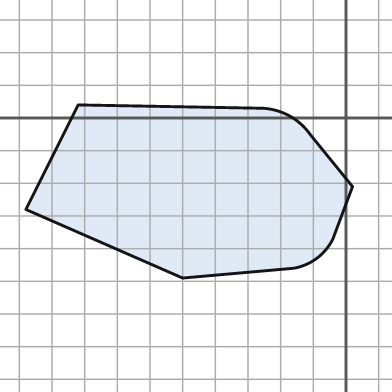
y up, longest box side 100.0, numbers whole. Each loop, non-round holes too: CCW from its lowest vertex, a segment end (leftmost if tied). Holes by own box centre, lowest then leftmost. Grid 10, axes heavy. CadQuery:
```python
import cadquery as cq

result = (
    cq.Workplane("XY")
    .moveTo(-50.0, -49.0)
    .lineTo(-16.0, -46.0)
    .threePointArc((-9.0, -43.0), (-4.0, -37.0))
    .lineTo(2.0, -21.0)
    .lineTo(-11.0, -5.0)
    .threePointArc((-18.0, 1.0), (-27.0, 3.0))
    .lineTo(-82.0, 4.0)
    .lineTo(-98.0, -28.0)
    .close()
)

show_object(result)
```